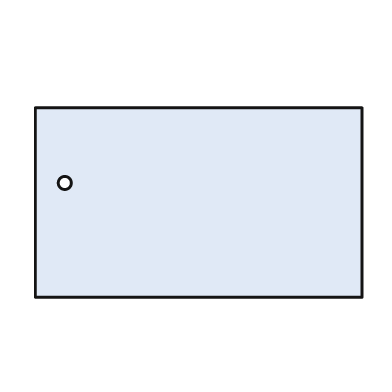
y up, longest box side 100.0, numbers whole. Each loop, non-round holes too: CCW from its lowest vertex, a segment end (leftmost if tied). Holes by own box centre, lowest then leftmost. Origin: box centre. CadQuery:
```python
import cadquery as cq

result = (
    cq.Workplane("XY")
    .moveTo(-50.0, -29.0)
    .lineTo(50.0, -29.0)
    .lineTo(50.0, 29.0)
    .lineTo(-50.0, 29.0)
    .close()
    .moveTo(-41.0, 6.0)
    .circle(2.0)
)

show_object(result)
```